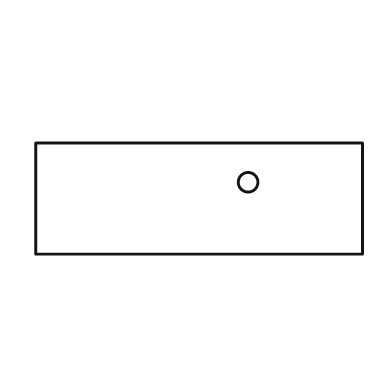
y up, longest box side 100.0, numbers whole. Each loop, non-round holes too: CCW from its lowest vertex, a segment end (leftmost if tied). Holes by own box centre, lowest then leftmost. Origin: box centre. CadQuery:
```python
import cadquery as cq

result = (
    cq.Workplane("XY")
    .moveTo(-50.0, -17.0)
    .lineTo(50.0, -17.0)
    .lineTo(50.0, 17.0)
    .lineTo(-50.0, 17.0)
    .close()
    .moveTo(15.0, 5.0)
    .circle(3.0)
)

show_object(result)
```